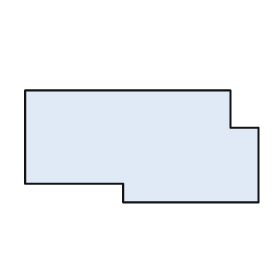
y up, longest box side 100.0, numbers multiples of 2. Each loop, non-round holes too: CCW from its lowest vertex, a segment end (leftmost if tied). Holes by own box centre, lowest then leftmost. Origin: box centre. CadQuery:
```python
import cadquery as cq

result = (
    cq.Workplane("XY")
    .moveTo(-8.0, -24.0)
    .lineTo(50.0, -24.0)
    .lineTo(50.0, 8.0)
    .lineTo(38.0, 8.0)
    .lineTo(38.0, 24.0)
    .lineTo(-50.0, 24.0)
    .lineTo(-50.0, -16.0)
    .lineTo(-8.0, -16.0)
    .close()
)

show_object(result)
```